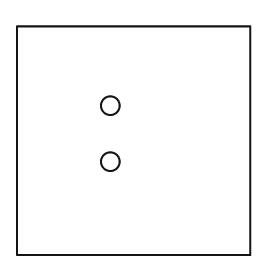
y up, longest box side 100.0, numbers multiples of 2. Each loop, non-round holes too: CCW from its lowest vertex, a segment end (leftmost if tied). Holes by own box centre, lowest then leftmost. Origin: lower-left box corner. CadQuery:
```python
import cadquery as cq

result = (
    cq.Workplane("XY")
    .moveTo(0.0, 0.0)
    .lineTo(100.0, 0.0)
    .lineTo(100.0, 98.0)
    .lineTo(0.0, 98.0)
    .close()
    .moveTo(40.0, 40.0)
    .circle(4.0)
    .moveTo(40.0, 64.0)
    .circle(4.0)
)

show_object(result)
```